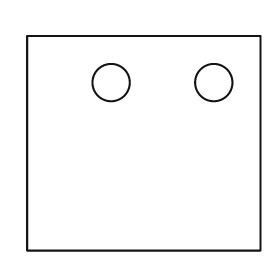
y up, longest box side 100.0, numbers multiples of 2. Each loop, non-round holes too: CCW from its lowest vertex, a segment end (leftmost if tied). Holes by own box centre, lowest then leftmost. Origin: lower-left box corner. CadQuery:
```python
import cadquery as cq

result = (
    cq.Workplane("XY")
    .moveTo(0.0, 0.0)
    .lineTo(100.0, 0.0)
    .lineTo(100.0, 92.0)
    .lineTo(0.0, 92.0)
    .close()
    .moveTo(36.0, 72.0)
    .circle(8.0)
    .moveTo(80.0, 72.0)
    .circle(8.0)
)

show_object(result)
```